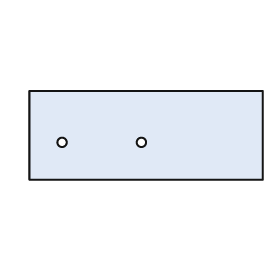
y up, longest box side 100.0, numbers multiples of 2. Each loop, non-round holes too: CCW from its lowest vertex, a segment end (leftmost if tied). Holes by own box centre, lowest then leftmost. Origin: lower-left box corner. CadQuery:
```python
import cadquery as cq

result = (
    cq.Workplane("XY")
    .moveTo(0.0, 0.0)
    .lineTo(100.0, 0.0)
    .lineTo(100.0, 38.0)
    .lineTo(0.0, 38.0)
    .close()
    .moveTo(14.0, 16.0)
    .circle(2.0)
    .moveTo(48.0, 16.0)
    .circle(2.0)
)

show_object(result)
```